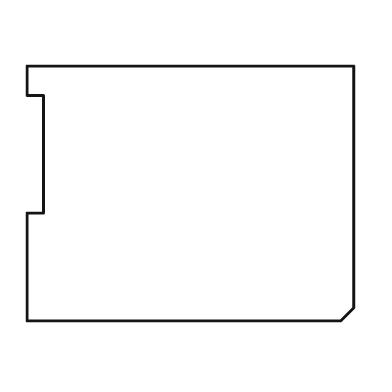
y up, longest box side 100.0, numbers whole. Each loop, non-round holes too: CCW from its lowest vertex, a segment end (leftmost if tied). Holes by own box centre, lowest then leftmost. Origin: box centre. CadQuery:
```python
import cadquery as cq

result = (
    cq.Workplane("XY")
    .moveTo(-50.0, -39.0)
    .lineTo(46.0, -39.0)
    .lineTo(50.0, -35.0)
    .lineTo(50.0, 39.0)
    .lineTo(-50.0, 39.0)
    .lineTo(-50.0, 30.0)
    .lineTo(-45.0, 30.0)
    .lineTo(-45.0, -6.0)
    .lineTo(-50.0, -6.0)
    .close()
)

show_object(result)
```